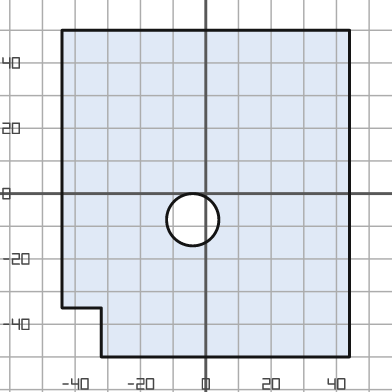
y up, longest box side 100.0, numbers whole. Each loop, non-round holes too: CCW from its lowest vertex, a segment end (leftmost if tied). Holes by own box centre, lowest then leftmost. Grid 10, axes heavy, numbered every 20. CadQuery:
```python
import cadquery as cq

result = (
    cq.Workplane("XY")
    .moveTo(-32.0, -50.0)
    .lineTo(44.0, -50.0)
    .lineTo(44.0, 50.0)
    .lineTo(-44.0, 50.0)
    .lineTo(-44.0, -35.0)
    .lineTo(-32.0, -35.0)
    .close()
    .moveTo(-4.0, -8.0)
    .circle(8.0)
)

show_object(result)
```